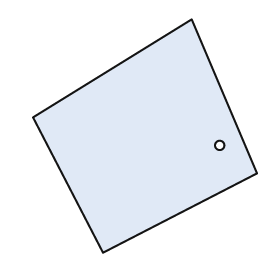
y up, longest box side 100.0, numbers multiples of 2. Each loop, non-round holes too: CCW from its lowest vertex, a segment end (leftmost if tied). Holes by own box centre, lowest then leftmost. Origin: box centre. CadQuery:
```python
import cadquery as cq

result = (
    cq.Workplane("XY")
    .moveTo(-18.0, -50.0)
    .lineTo(48.0, -16.0)
    .lineTo(20.0, 50.0)
    .lineTo(-48.0, 8.0)
    .close()
    .moveTo(32.0, -4.0)
    .circle(2.0)
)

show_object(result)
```